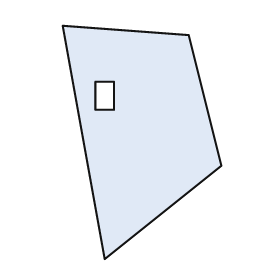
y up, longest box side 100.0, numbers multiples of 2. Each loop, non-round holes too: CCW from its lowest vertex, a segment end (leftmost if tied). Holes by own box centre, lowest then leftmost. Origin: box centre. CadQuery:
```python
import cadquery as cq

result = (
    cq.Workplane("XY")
    .moveTo(-16.0, -50.0)
    .lineTo(34.0, -10.0)
    .lineTo(20.0, 46.0)
    .lineTo(-34.0, 50.0)
    .close()
    .moveTo(-20.0, 14.0)
    .lineTo(-12.0, 14.0)
    .lineTo(-12.0, 26.0)
    .lineTo(-20.0, 26.0)
    .close()
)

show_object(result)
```